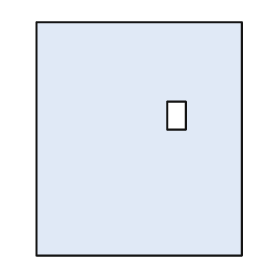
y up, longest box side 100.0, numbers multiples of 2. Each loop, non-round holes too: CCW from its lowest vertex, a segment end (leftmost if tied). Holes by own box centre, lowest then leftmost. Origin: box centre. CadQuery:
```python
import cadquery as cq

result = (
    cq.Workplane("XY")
    .moveTo(-44.0, -50.0)
    .lineTo(44.0, -50.0)
    .lineTo(44.0, 50.0)
    .lineTo(-44.0, 50.0)
    .close()
    .moveTo(12.0, 4.0)
    .lineTo(20.0, 4.0)
    .lineTo(20.0, 16.0)
    .lineTo(12.0, 16.0)
    .close()
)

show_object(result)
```